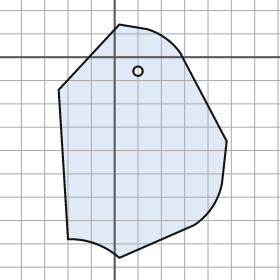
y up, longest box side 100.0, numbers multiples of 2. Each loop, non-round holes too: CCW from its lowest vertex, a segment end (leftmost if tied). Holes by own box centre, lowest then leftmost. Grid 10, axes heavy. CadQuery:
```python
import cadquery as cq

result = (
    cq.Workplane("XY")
    .moveTo(2.0, -86.0)
    .lineTo(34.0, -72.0)
    .threePointArc((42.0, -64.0), (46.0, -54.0))
    .lineTo(48.0, -36.0)
    .lineTo(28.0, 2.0)
    .threePointArc((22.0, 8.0), (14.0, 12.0))
    .lineTo(2.0, 14.0)
    .lineTo(-24.0, -14.0)
    .lineTo(-20.0, -78.0)
    .threePointArc((-8.0, -80.0), (2.0, -86.0))
    .close()
    .moveTo(10.0, -6.0)
    .circle(2.0)
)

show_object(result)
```